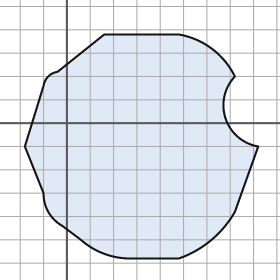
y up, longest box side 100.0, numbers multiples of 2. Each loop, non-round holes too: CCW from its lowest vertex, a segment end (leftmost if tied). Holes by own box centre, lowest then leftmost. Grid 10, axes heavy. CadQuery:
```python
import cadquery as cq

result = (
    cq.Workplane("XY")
    .moveTo(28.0, -58.0)
    .lineTo(48.0, -58.0)
    .threePointArc((62.0, -50.0), (72.0, -38.0))
    .lineTo(82.0, -10.0)
    .threePointArc((68.0, 2.0), (72.0, 20.0))
    .threePointArc((62.0, 32.0), (48.0, 38.0))
    .lineTo(16.0, 38.0)
    .lineTo(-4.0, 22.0)
    .threePointArc((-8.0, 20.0), (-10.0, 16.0))
    .lineTo(-18.0, -10.0)
    .lineTo(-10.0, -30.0)
    .threePointArc((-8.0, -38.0), (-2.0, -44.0))
    .lineTo(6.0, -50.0)
    .threePointArc((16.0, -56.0), (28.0, -58.0))
    .close()
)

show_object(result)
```